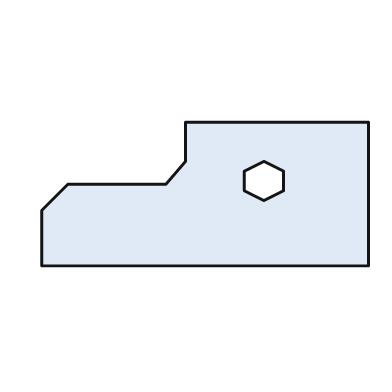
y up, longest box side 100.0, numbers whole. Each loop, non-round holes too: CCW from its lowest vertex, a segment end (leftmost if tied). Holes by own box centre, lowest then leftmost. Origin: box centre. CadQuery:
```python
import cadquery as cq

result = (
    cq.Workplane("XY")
    .moveTo(-50.0, -22.0)
    .lineTo(50.0, -22.0)
    .lineTo(50.0, 22.0)
    .lineTo(-6.0, 22.0)
    .lineTo(-6.0, 10.0)
    .lineTo(-12.0, 3.0)
    .lineTo(-42.0, 3.0)
    .lineTo(-50.0, -5.0)
    .close()
    .moveTo(18.0, -2.0)
    .lineTo(24.0, 1.0)
    .lineTo(24.0, 7.0)
    .lineTo(18.0, 10.0)
    .lineTo(12.0, 7.0)
    .lineTo(12.0, 1.0)
    .close()
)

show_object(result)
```